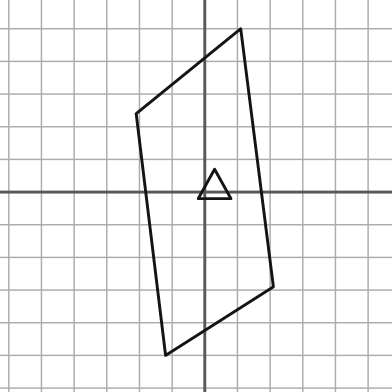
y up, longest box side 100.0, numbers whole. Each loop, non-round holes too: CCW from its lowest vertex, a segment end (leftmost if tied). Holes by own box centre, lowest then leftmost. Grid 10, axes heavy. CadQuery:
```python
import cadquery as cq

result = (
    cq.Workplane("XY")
    .moveTo(-12.0, -50.0)
    .lineTo(21.0, -29.0)
    .lineTo(11.0, 50.0)
    .lineTo(-21.0, 24.0)
    .close()
    .moveTo(-2.0, -2.0)
    .lineTo(8.0, -2.0)
    .lineTo(3.0, 7.0)
    .close()
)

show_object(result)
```